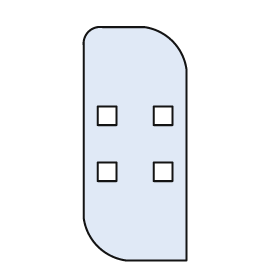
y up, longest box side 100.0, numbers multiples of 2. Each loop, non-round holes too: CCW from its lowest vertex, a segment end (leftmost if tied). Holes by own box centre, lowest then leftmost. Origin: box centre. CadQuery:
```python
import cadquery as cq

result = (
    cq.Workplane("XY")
    .moveTo(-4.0, -50.0)
    .lineTo(22.0, -50.0)
    .lineTo(22.0, 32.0)
    .threePointArc((16.0, 44.0), (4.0, 50.0))
    .lineTo(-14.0, 50.0)
    .threePointArc((-20.0, 48.0), (-22.0, 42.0))
    .lineTo(-22.0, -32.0)
    .threePointArc((-16.0, -44.0), (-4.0, -50.0))
    .close()
    .moveTo(-16.0, -16.0)
    .lineTo(-8.0, -16.0)
    .lineTo(-8.0, -8.0)
    .lineTo(-16.0, -8.0)
    .close()
    .moveTo(8.0, -16.0)
    .lineTo(16.0, -16.0)
    .lineTo(16.0, -8.0)
    .lineTo(8.0, -8.0)
    .close()
    .moveTo(-16.0, 8.0)
    .lineTo(-8.0, 8.0)
    .lineTo(-8.0, 16.0)
    .lineTo(-16.0, 16.0)
    .close()
    .moveTo(8.0, 8.0)
    .lineTo(16.0, 8.0)
    .lineTo(16.0, 16.0)
    .lineTo(8.0, 16.0)
    .close()
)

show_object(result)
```